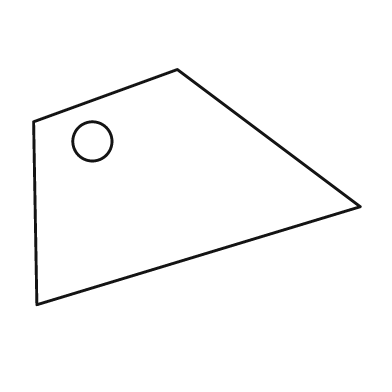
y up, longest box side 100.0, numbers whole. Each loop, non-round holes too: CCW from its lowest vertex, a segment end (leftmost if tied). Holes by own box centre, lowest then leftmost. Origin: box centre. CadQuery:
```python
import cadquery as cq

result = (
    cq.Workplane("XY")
    .moveTo(-49.0, -36.0)
    .lineTo(50.0, -6.0)
    .lineTo(-6.0, 36.0)
    .lineTo(-50.0, 20.0)
    .close()
    .moveTo(-32.0, 14.0)
    .circle(6.0)
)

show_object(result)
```